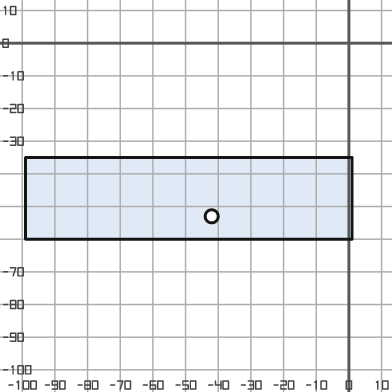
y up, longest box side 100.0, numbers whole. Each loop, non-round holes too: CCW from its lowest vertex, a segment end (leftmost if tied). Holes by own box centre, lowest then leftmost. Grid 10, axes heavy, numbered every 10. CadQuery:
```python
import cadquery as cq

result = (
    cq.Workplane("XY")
    .moveTo(-99.0, -60.0)
    .lineTo(1.0, -60.0)
    .lineTo(1.0, -35.0)
    .lineTo(-99.0, -35.0)
    .close()
    .moveTo(-42.0, -53.0)
    .circle(2.0)
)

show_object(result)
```